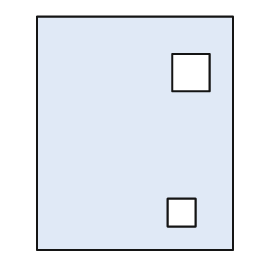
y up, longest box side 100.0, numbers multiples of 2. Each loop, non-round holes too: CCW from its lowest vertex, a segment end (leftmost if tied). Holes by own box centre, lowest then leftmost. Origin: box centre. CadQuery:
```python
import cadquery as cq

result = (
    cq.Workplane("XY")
    .moveTo(-42.0, -50.0)
    .lineTo(42.0, -50.0)
    .lineTo(42.0, 50.0)
    .lineTo(-42.0, 50.0)
    .close()
    .moveTo(14.0, -40.0)
    .lineTo(26.0, -40.0)
    .lineTo(26.0, -28.0)
    .lineTo(14.0, -28.0)
    .close()
    .moveTo(16.0, 18.0)
    .lineTo(32.0, 18.0)
    .lineTo(32.0, 34.0)
    .lineTo(16.0, 34.0)
    .close()
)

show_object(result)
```